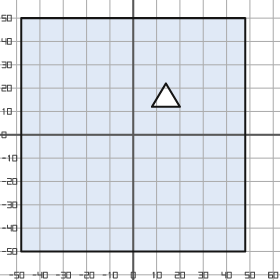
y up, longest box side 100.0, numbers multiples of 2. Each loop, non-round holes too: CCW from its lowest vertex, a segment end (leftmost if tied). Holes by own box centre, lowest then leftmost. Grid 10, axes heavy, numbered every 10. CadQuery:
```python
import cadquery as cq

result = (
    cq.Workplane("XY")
    .moveTo(-48.0, -50.0)
    .lineTo(48.0, -50.0)
    .lineTo(48.0, 50.0)
    .lineTo(-48.0, 50.0)
    .close()
    .moveTo(8.0, 12.0)
    .lineTo(20.0, 12.0)
    .lineTo(14.0, 22.0)
    .close()
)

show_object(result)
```